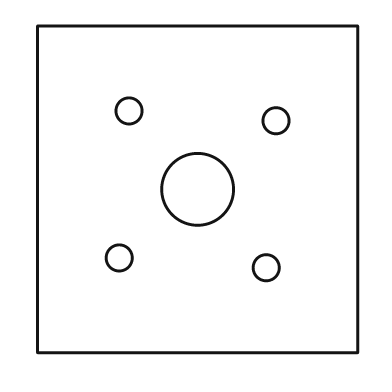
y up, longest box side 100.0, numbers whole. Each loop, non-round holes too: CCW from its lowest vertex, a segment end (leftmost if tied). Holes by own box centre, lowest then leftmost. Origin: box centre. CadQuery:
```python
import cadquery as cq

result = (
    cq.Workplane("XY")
    .moveTo(-49.0, -50.0)
    .lineTo(49.0, -50.0)
    .lineTo(49.0, 50.0)
    .lineTo(-49.0, 50.0)
    .close()
    .moveTo(21.0, -24.0)
    .circle(4.0)
    .moveTo(-24.0, -21.0)
    .circle(4.0)
    .moveTo(0.0, 0.0)
    .circle(11.0)
    .moveTo(24.0, 21.0)
    .circle(4.0)
    .moveTo(-21.0, 24.0)
    .circle(4.0)
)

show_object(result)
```